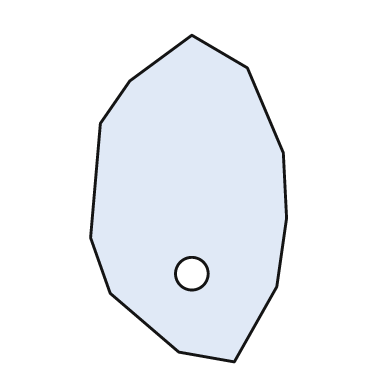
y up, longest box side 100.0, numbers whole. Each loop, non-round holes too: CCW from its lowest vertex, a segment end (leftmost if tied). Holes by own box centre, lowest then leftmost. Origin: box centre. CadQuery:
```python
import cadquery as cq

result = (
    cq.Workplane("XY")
    .moveTo(14.0, -50.0)
    .lineTo(27.0, -27.0)
    .lineTo(30.0, -6.0)
    .lineTo(29.0, 14.0)
    .lineTo(18.0, 40.0)
    .lineTo(1.0, 50.0)
    .lineTo(-18.0, 36.0)
    .lineTo(-27.0, 23.0)
    .lineTo(-30.0, -12.0)
    .lineTo(-24.0, -29.0)
    .lineTo(-3.0, -47.0)
    .close()
    .moveTo(1.0, -23.0)
    .circle(5.0)
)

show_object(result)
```